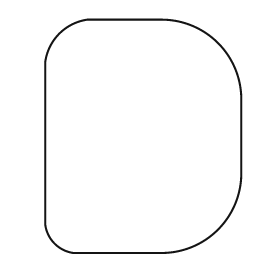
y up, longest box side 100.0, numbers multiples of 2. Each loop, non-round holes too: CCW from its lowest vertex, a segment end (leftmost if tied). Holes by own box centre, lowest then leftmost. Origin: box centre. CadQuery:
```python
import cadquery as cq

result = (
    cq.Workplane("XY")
    .moveTo(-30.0, -50.0)
    .lineTo(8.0, -50.0)
    .threePointArc((32.0, -40.0), (42.0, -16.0))
    .lineTo(42.0, 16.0)
    .threePointArc((32.0, 40.0), (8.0, 50.0))
    .lineTo(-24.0, 50.0)
    .threePointArc((-36.0, 44.0), (-42.0, 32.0))
    .lineTo(-42.0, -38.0)
    .threePointArc((-38.0, -46.0), (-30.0, -50.0))
    .close()
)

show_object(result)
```